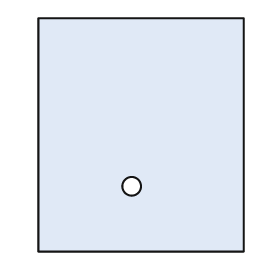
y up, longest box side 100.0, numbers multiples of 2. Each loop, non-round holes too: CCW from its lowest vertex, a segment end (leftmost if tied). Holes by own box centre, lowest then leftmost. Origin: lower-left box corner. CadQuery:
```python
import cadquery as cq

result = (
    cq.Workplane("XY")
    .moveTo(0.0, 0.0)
    .lineTo(88.0, 0.0)
    .lineTo(88.0, 100.0)
    .lineTo(0.0, 100.0)
    .close()
    .moveTo(40.0, 28.0)
    .circle(4.0)
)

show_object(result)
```